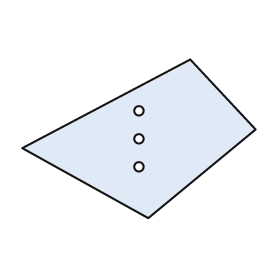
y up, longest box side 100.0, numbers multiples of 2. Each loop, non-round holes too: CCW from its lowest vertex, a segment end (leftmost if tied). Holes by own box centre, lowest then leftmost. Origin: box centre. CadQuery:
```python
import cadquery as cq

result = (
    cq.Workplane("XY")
    .moveTo(4.0, -34.0)
    .lineTo(50.0, 4.0)
    .lineTo(22.0, 34.0)
    .lineTo(-50.0, -4.0)
    .close()
    .moveTo(0.0, -12.0)
    .circle(2.0)
    .moveTo(0.0, 0.0)
    .circle(2.0)
    .moveTo(0.0, 12.0)
    .circle(2.0)
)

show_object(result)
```